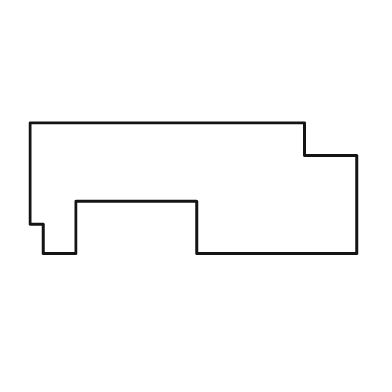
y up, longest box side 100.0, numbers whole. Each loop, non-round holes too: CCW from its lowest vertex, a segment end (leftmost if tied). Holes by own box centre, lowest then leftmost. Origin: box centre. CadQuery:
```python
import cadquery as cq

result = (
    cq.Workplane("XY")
    .moveTo(-46.0, -20.0)
    .lineTo(-36.0, -20.0)
    .lineTo(-36.0, -4.0)
    .lineTo(1.0, -4.0)
    .lineTo(1.0, -20.0)
    .lineTo(50.0, -20.0)
    .lineTo(50.0, 10.0)
    .lineTo(34.0, 10.0)
    .lineTo(34.0, 20.0)
    .lineTo(-50.0, 20.0)
    .lineTo(-50.0, -11.0)
    .lineTo(-46.0, -11.0)
    .close()
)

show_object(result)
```